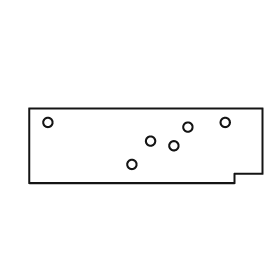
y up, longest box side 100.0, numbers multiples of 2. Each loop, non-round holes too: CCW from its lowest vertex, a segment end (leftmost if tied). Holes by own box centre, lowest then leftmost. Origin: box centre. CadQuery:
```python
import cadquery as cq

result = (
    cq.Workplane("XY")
    .moveTo(-50.0, -16.0)
    .lineTo(38.0, -16.0)
    .lineTo(38.0, -12.0)
    .lineTo(50.0, -12.0)
    .lineTo(50.0, 16.0)
    .lineTo(-50.0, 16.0)
    .close()
    .moveTo(-6.0, -8.0)
    .circle(2.0)
    .moveTo(12.0, 0.0)
    .circle(2.0)
    .moveTo(2.0, 2.0)
    .circle(2.0)
    .moveTo(18.0, 8.0)
    .circle(2.0)
    .moveTo(-42.0, 10.0)
    .circle(2.0)
    .moveTo(34.0, 10.0)
    .circle(2.0)
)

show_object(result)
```